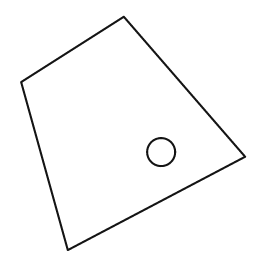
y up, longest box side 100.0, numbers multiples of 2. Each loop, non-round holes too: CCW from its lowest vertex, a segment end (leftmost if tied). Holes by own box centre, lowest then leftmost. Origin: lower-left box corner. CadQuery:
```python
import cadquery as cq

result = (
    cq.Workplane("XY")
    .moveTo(20.0, 0.0)
    .lineTo(96.0, 40.0)
    .lineTo(44.0, 100.0)
    .lineTo(0.0, 72.0)
    .close()
    .moveTo(60.0, 42.0)
    .circle(6.0)
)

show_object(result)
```